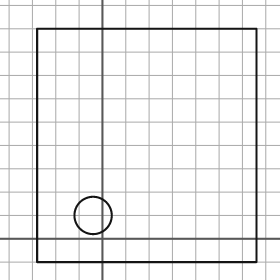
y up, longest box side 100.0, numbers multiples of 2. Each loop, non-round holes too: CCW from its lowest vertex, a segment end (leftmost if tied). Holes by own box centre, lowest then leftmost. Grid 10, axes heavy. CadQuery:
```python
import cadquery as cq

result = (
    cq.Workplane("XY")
    .moveTo(-28.0, -10.0)
    .lineTo(66.0, -10.0)
    .lineTo(66.0, 90.0)
    .lineTo(-28.0, 90.0)
    .close()
    .moveTo(-4.0, 10.0)
    .circle(8.0)
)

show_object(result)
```